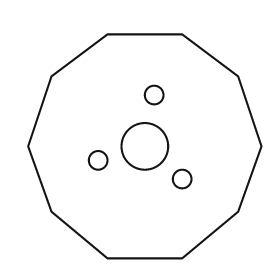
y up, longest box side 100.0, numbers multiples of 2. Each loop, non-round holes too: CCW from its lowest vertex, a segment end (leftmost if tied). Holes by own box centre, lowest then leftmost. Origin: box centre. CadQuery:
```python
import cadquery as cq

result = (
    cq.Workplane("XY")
    .moveTo(-16.0, -48.0)
    .lineTo(16.0, -48.0)
    .lineTo(40.0, -28.0)
    .lineTo(50.0, 0.0)
    .lineTo(40.0, 30.0)
    .lineTo(16.0, 48.0)
    .lineTo(-16.0, 48.0)
    .lineTo(-40.0, 30.0)
    .lineTo(-50.0, 0.0)
    .lineTo(-40.0, -28.0)
    .close()
    .moveTo(16.0, -14.0)
    .circle(4.0)
    .moveTo(-20.0, -6.0)
    .circle(4.0)
    .moveTo(0.0, 0.0)
    .circle(10.0)
    .moveTo(4.0, 22.0)
    .circle(4.0)
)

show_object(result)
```